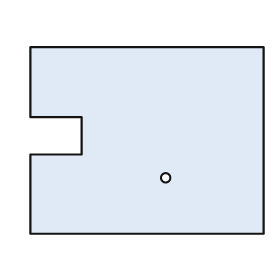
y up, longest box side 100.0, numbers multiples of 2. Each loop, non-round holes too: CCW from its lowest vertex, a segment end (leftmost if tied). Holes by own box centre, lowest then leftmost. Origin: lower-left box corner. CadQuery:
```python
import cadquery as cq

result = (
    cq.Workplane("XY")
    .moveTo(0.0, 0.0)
    .lineTo(100.0, 0.0)
    .lineTo(100.0, 80.0)
    .lineTo(0.0, 80.0)
    .lineTo(0.0, 50.0)
    .lineTo(22.0, 50.0)
    .lineTo(22.0, 34.0)
    .lineTo(0.0, 34.0)
    .close()
    .moveTo(58.0, 24.0)
    .circle(2.0)
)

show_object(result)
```